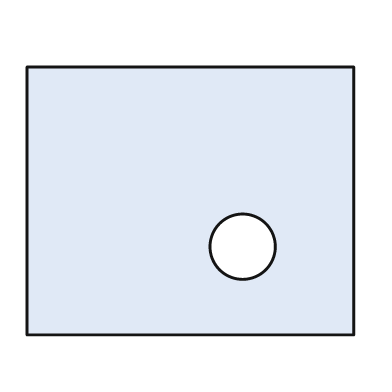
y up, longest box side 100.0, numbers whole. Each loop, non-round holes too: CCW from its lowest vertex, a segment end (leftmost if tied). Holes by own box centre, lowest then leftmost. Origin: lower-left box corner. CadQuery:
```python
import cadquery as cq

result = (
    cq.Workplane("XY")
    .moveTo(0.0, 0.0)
    .lineTo(100.0, 0.0)
    .lineTo(100.0, 82.0)
    .lineTo(0.0, 82.0)
    .close()
    .moveTo(66.0, 27.0)
    .circle(10.0)
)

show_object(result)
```